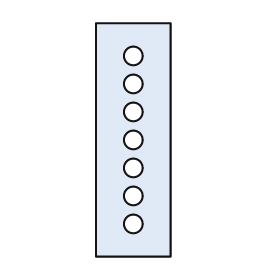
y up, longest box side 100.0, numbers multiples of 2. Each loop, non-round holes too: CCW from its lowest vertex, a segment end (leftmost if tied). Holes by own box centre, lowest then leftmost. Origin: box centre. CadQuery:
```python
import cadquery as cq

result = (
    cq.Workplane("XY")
    .moveTo(-16.0, -50.0)
    .lineTo(16.0, -50.0)
    .lineTo(16.0, 50.0)
    .lineTo(-16.0, 50.0)
    .close()
    .moveTo(0.0, -36.0)
    .circle(4.0)
    .moveTo(0.0, -24.0)
    .circle(4.0)
    .moveTo(0.0, -12.0)
    .circle(4.0)
    .moveTo(0.0, 0.0)
    .circle(4.0)
    .moveTo(0.0, 12.0)
    .circle(4.0)
    .moveTo(0.0, 24.0)
    .circle(4.0)
    .moveTo(0.0, 36.0)
    .circle(4.0)
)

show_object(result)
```